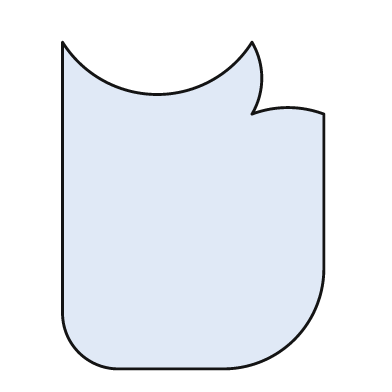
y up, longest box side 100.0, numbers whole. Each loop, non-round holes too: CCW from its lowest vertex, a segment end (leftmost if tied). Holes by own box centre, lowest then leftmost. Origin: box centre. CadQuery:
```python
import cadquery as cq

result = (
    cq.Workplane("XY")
    .moveTo(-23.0, -50.0)
    .lineTo(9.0, -50.0)
    .threePointArc((31.0, -41.0), (40.0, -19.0))
    .lineTo(40.0, 28.0)
    .threePointArc((29.0, 30.0), (18.0, 28.0))
    .threePointArc((21.0, 39.0), (18.0, 50.0))
    .threePointArc((-11.0, 34.0), (-40.0, 50.0))
    .lineTo(-40.0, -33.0)
    .threePointArc((-35.0, -45.0), (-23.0, -50.0))
    .close()
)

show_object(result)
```